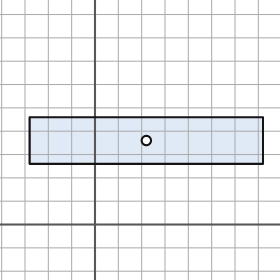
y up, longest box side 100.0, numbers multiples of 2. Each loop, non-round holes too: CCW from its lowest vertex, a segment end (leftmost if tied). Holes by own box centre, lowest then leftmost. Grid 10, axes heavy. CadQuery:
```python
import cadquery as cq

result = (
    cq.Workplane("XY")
    .moveTo(-28.0, 26.0)
    .lineTo(72.0, 26.0)
    .lineTo(72.0, 46.0)
    .lineTo(-28.0, 46.0)
    .close()
    .moveTo(22.0, 36.0)
    .circle(2.0)
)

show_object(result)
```